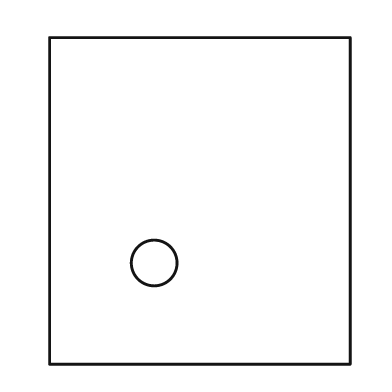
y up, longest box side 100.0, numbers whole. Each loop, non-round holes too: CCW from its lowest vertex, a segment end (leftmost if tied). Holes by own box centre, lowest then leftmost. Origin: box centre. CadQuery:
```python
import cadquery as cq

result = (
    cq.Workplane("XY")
    .moveTo(-46.0, -50.0)
    .lineTo(46.0, -50.0)
    .lineTo(46.0, 50.0)
    .lineTo(-46.0, 50.0)
    .close()
    .moveTo(-14.0, -19.0)
    .circle(7.0)
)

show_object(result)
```